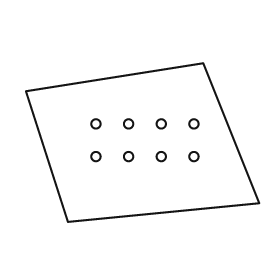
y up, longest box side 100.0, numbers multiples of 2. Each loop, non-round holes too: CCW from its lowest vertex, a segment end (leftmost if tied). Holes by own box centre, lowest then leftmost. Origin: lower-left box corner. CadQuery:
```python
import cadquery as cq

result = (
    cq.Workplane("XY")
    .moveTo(18.0, 0.0)
    .lineTo(100.0, 8.0)
    .lineTo(76.0, 68.0)
    .lineTo(0.0, 56.0)
    .close()
    .moveTo(30.0, 28.0)
    .circle(2.0)
    .moveTo(44.0, 28.0)
    .circle(2.0)
    .moveTo(58.0, 28.0)
    .circle(2.0)
    .moveTo(72.0, 28.0)
    .circle(2.0)
    .moveTo(30.0, 42.0)
    .circle(2.0)
    .moveTo(44.0, 42.0)
    .circle(2.0)
    .moveTo(58.0, 42.0)
    .circle(2.0)
    .moveTo(72.0, 42.0)
    .circle(2.0)
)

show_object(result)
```